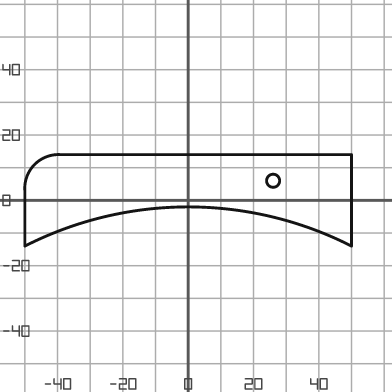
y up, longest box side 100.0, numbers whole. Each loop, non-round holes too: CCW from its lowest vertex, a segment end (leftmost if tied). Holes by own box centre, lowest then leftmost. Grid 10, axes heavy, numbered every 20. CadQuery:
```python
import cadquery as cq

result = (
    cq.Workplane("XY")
    .moveTo(-50.0, -14.0)
    .threePointArc((0.0, -2.0), (50.0, -14.0))
    .lineTo(50.0, 14.0)
    .lineTo(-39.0, 14.0)
    .threePointArc((-47.0, 11.0), (-50.0, 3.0))
    .close()
    .moveTo(26.0, 6.0)
    .circle(2.0)
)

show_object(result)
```